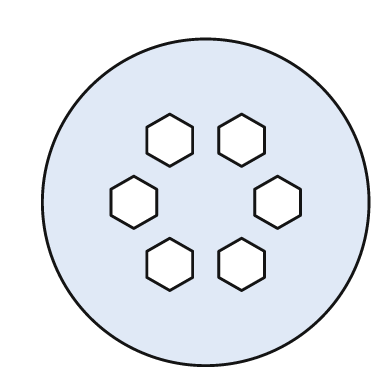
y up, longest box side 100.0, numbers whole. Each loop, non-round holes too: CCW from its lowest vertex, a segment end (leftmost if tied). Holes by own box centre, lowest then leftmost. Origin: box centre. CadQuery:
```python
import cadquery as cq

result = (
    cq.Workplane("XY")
    .moveTo(0.0, 0.0)
    .circle(50.0)
    .moveTo(-11.0, -27.0)
    .lineTo(-4.0, -23.0)
    .lineTo(-4.0, -15.0)
    .lineTo(-11.0, -11.0)
    .lineTo(-18.0, -15.0)
    .lineTo(-18.0, -23.0)
    .close()
    .moveTo(11.0, -27.0)
    .lineTo(18.0, -23.0)
    .lineTo(18.0, -15.0)
    .lineTo(11.0, -11.0)
    .lineTo(4.0, -15.0)
    .lineTo(4.0, -23.0)
    .close()
    .moveTo(-22.0, -8.0)
    .lineTo(-15.0, -4.0)
    .lineTo(-15.0, 4.0)
    .lineTo(-22.0, 8.0)
    .lineTo(-29.0, 4.0)
    .lineTo(-29.0, -4.0)
    .close()
    .moveTo(22.0, -8.0)
    .lineTo(29.0, -4.0)
    .lineTo(29.0, 4.0)
    .lineTo(22.0, 8.0)
    .lineTo(15.0, 4.0)
    .lineTo(15.0, -4.0)
    .close()
    .moveTo(-11.0, 11.0)
    .lineTo(-4.0, 15.0)
    .lineTo(-4.0, 23.0)
    .lineTo(-11.0, 27.0)
    .lineTo(-18.0, 23.0)
    .lineTo(-18.0, 15.0)
    .close()
    .moveTo(11.0, 11.0)
    .lineTo(18.0, 15.0)
    .lineTo(18.0, 23.0)
    .lineTo(11.0, 27.0)
    .lineTo(4.0, 23.0)
    .lineTo(4.0, 15.0)
    .close()
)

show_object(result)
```